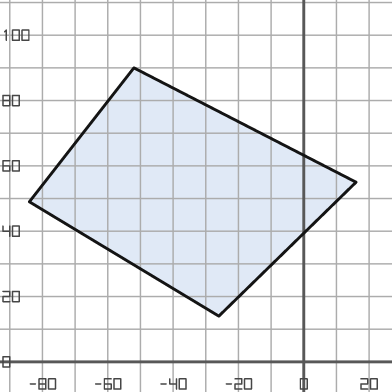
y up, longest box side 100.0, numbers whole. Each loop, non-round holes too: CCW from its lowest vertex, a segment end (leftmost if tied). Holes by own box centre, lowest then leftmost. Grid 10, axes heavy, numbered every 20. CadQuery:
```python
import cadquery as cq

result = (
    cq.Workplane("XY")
    .moveTo(-26.0, 14.0)
    .lineTo(16.0, 55.0)
    .lineTo(-52.0, 90.0)
    .lineTo(-84.0, 49.0)
    .close()
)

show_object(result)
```